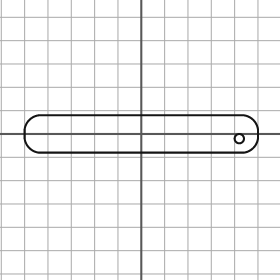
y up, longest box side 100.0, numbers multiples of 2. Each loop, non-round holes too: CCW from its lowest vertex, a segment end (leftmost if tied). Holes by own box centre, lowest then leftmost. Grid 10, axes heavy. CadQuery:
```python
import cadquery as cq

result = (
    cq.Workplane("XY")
    .moveTo(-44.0, -8.0)
    .lineTo(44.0, -8.0)
    .threePointArc((48.0, -6.0), (50.0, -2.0))
    .lineTo(50.0, 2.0)
    .threePointArc((48.0, 6.0), (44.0, 8.0))
    .lineTo(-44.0, 8.0)
    .threePointArc((-48.0, 6.0), (-50.0, 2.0))
    .lineTo(-50.0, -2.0)
    .threePointArc((-48.0, -6.0), (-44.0, -8.0))
    .close()
    .moveTo(42.0, -2.0)
    .circle(2.0)
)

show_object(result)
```